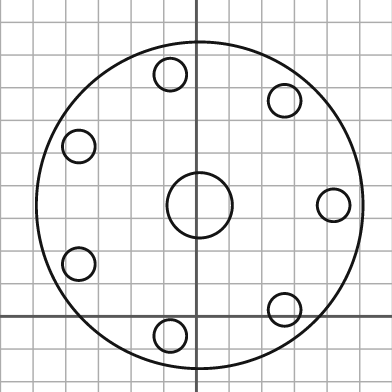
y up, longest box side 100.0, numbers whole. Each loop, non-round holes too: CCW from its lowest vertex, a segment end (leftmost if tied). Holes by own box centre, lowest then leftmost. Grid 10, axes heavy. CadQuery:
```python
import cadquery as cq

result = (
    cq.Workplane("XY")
    .moveTo(1.0, 34.0)
    .circle(50.0)
    .moveTo(-8.0, -6.0)
    .circle(5.0)
    .moveTo(27.0, 2.0)
    .circle(5.0)
    .moveTo(-36.0, 16.0)
    .circle(5.0)
    .moveTo(1.0, 34.0)
    .circle(10.0)
    .moveTo(42.0, 34.0)
    .circle(5.0)
    .moveTo(-36.0, 52.0)
    .circle(5.0)
    .moveTo(27.0, 66.0)
    .circle(5.0)
    .moveTo(-8.0, 74.0)
    .circle(5.0)
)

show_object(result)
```